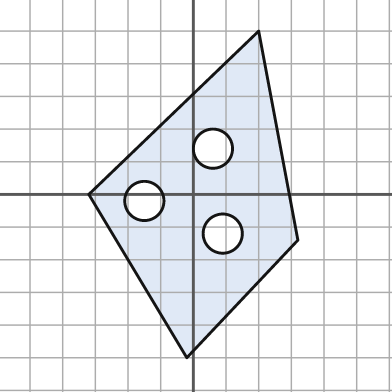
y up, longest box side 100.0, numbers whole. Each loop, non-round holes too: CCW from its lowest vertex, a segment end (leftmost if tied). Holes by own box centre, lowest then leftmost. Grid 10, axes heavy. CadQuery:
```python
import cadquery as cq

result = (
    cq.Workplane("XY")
    .moveTo(-2.0, -50.0)
    .lineTo(32.0, -14.0)
    .lineTo(20.0, 50.0)
    .lineTo(-32.0, 0.0)
    .close()
    .moveTo(9.0, -12.0)
    .circle(6.0)
    .moveTo(-15.0, -2.0)
    .circle(6.0)
    .moveTo(6.0, 14.0)
    .circle(6.0)
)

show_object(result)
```